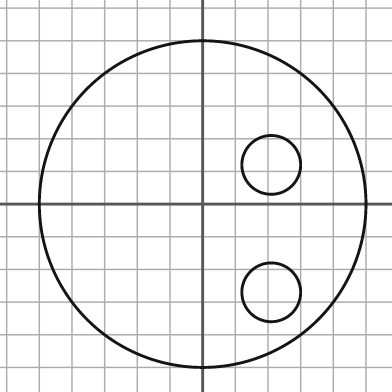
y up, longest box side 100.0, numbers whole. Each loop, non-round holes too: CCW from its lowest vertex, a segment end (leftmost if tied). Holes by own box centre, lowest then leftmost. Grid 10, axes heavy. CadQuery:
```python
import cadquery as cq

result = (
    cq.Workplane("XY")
    .moveTo(0.0, 0.0)
    .circle(50.0)
    .moveTo(21.0, -27.0)
    .circle(9.0)
    .moveTo(21.0, 12.0)
    .circle(9.0)
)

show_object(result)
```